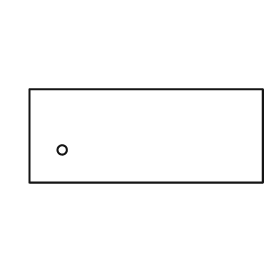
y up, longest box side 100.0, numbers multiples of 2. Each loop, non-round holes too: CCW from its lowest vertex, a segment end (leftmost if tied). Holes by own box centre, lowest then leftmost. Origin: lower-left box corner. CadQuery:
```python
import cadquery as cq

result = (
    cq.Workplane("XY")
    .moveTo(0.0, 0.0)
    .lineTo(100.0, 0.0)
    .lineTo(100.0, 40.0)
    .lineTo(0.0, 40.0)
    .close()
    .moveTo(14.0, 14.0)
    .circle(2.0)
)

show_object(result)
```